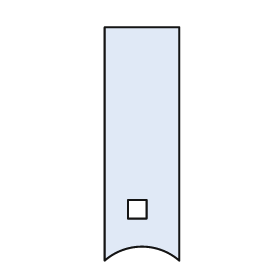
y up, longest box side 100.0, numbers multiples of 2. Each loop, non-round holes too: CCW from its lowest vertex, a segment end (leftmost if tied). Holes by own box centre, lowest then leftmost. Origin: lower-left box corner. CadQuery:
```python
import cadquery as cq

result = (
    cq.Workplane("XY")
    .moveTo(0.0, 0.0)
    .threePointArc((16.0, 6.0), (32.0, 0.0))
    .lineTo(32.0, 100.0)
    .lineTo(0.0, 100.0)
    .close()
    .moveTo(10.0, 18.0)
    .lineTo(18.0, 18.0)
    .lineTo(18.0, 26.0)
    .lineTo(10.0, 26.0)
    .close()
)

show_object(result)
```